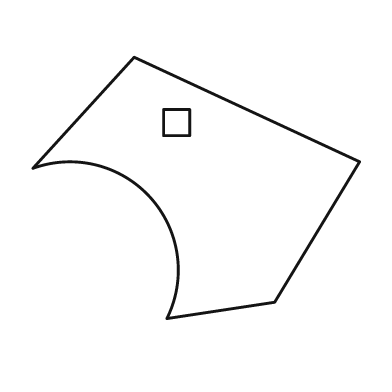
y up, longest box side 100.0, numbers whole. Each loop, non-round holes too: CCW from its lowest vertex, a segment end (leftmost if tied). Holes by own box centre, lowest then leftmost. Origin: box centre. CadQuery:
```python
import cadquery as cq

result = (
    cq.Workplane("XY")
    .moveTo(-9.0, -40.0)
    .lineTo(24.0, -35.0)
    .lineTo(50.0, 8.0)
    .lineTo(-19.0, 40.0)
    .lineTo(-50.0, 6.0)
    .threePointArc((-14.0, -3.0), (-9.0, -40.0))
    .close()
    .moveTo(-10.0, 16.0)
    .lineTo(-2.0, 16.0)
    .lineTo(-2.0, 24.0)
    .lineTo(-10.0, 24.0)
    .close()
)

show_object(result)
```